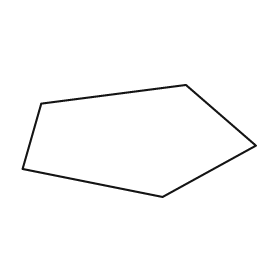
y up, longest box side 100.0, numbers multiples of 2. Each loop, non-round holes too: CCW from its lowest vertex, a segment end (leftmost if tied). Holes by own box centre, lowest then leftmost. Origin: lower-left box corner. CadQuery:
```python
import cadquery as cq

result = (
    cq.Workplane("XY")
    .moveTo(60.0, 0.0)
    .lineTo(100.0, 22.0)
    .lineTo(70.0, 48.0)
    .lineTo(8.0, 40.0)
    .lineTo(0.0, 12.0)
    .close()
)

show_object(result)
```